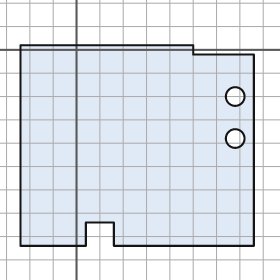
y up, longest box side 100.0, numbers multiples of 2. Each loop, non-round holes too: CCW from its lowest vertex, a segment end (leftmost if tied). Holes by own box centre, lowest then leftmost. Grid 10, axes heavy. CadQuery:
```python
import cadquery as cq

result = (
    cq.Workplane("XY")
    .moveTo(-24.0, -84.0)
    .lineTo(4.0, -84.0)
    .lineTo(4.0, -74.0)
    .lineTo(16.0, -74.0)
    .lineTo(16.0, -84.0)
    .lineTo(76.0, -84.0)
    .lineTo(76.0, -2.0)
    .lineTo(50.0, -2.0)
    .lineTo(50.0, 2.0)
    .lineTo(-24.0, 2.0)
    .close()
    .moveTo(68.0, -38.0)
    .circle(4.0)
    .moveTo(68.0, -20.0)
    .circle(4.0)
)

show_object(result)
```